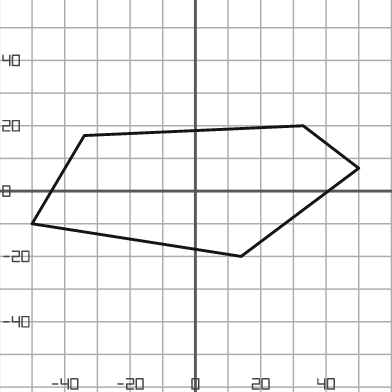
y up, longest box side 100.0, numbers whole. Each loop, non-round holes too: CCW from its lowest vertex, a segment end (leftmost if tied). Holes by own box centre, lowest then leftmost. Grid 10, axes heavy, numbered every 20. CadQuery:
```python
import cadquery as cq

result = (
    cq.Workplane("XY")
    .moveTo(14.0, -20.0)
    .lineTo(50.0, 7.0)
    .lineTo(33.0, 20.0)
    .lineTo(-34.0, 17.0)
    .lineTo(-50.0, -10.0)
    .close()
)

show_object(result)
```